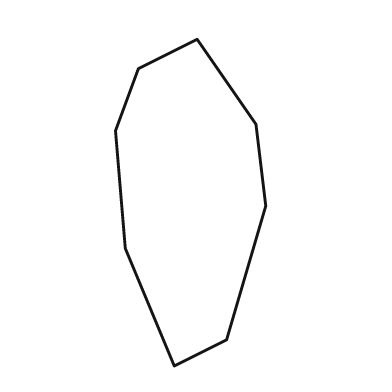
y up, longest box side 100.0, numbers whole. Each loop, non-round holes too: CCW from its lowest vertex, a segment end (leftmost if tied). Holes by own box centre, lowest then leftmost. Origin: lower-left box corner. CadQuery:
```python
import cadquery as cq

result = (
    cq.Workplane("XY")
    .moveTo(18.0, 0.0)
    .lineTo(34.0, 8.0)
    .lineTo(46.0, 49.0)
    .lineTo(43.0, 74.0)
    .lineTo(25.0, 100.0)
    .lineTo(7.0, 91.0)
    .lineTo(0.0, 72.0)
    .lineTo(3.0, 36.0)
    .close()
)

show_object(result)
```